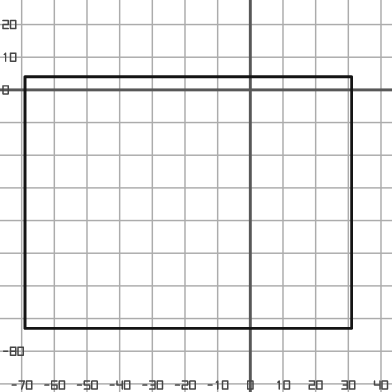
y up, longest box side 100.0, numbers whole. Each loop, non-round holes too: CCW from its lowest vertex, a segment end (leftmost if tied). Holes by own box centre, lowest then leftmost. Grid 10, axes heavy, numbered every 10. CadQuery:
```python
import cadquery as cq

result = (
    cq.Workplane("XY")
    .moveTo(-69.0, -73.0)
    .lineTo(31.0, -73.0)
    .lineTo(31.0, 4.0)
    .lineTo(-69.0, 4.0)
    .close()
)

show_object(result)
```